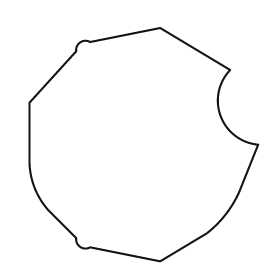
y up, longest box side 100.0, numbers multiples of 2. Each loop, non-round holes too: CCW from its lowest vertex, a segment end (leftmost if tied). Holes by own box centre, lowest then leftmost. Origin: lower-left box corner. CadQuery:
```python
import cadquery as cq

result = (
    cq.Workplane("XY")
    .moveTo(56.0, 0.0)
    .lineTo(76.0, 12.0)
    .threePointArc((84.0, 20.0), (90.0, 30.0))
    .lineTo(98.0, 50.0)
    .threePointArc((82.0, 62.0), (86.0, 82.0))
    .lineTo(56.0, 100.0)
    .lineTo(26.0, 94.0)
    .threePointArc((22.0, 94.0), (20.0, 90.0))
    .lineTo(0.0, 68.0)
    .lineTo(0.0, 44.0)
    .threePointArc((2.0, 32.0), (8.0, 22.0))
    .lineTo(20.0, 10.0)
    .threePointArc((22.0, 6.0), (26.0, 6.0))
    .close()
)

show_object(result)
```